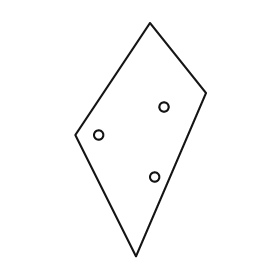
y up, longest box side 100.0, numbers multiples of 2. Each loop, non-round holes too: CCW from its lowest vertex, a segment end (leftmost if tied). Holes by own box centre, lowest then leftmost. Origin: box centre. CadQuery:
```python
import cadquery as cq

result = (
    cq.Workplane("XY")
    .moveTo(-2.0, -50.0)
    .lineTo(28.0, 20.0)
    .lineTo(4.0, 50.0)
    .lineTo(-28.0, 2.0)
    .close()
    .moveTo(6.0, -16.0)
    .circle(2.0)
    .moveTo(-18.0, 2.0)
    .circle(2.0)
    .moveTo(10.0, 14.0)
    .circle(2.0)
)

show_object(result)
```